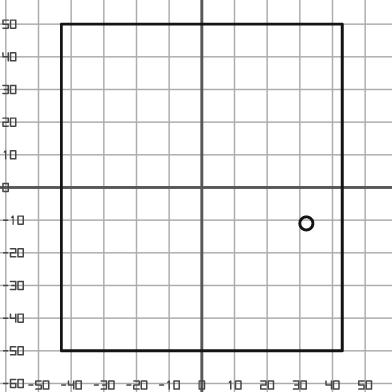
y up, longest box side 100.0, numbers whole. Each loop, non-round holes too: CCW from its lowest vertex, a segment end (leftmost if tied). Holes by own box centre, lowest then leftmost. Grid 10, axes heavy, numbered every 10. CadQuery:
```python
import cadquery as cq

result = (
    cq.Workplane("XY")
    .moveTo(-43.0, -50.0)
    .lineTo(43.0, -50.0)
    .lineTo(43.0, 50.0)
    .lineTo(-43.0, 50.0)
    .close()
    .moveTo(32.0, -11.0)
    .circle(2.0)
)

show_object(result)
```